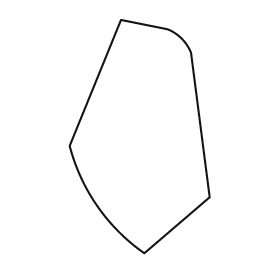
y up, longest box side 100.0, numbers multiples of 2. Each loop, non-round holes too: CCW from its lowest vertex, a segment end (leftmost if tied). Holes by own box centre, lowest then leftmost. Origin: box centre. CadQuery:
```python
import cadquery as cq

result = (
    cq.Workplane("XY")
    .moveTo(2.0, -50.0)
    .lineTo(30.0, -26.0)
    .lineTo(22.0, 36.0)
    .threePointArc((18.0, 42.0), (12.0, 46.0))
    .lineTo(-8.0, 50.0)
    .lineTo(-30.0, -4.0)
    .threePointArc((-18.0, -30.0), (2.0, -50.0))
    .close()
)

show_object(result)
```